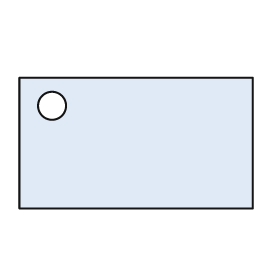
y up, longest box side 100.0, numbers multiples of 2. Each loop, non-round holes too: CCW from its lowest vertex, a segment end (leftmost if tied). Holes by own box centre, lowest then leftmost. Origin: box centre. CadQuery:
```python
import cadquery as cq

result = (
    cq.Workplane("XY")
    .moveTo(-50.0, -28.0)
    .lineTo(50.0, -28.0)
    .lineTo(50.0, 28.0)
    .lineTo(-50.0, 28.0)
    .close()
    .moveTo(-36.0, 16.0)
    .circle(6.0)
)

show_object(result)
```